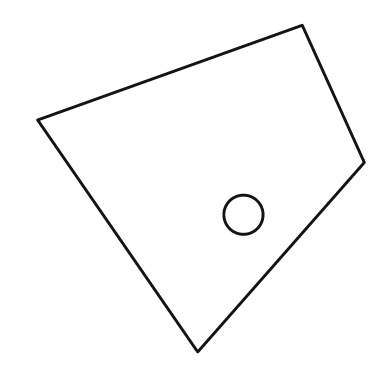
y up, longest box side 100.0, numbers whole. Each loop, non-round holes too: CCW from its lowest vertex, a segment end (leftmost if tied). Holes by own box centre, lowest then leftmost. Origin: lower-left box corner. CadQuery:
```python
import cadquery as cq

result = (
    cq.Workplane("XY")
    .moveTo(49.0, 0.0)
    .lineTo(100.0, 58.0)
    .lineTo(81.0, 100.0)
    .lineTo(0.0, 71.0)
    .close()
    .moveTo(63.0, 42.0)
    .circle(6.0)
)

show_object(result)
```